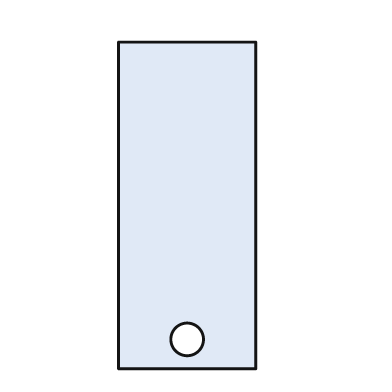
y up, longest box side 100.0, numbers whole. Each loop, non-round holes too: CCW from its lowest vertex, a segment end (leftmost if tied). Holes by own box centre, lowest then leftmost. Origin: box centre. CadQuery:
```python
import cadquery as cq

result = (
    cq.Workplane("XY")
    .moveTo(-21.0, -50.0)
    .lineTo(21.0, -50.0)
    .lineTo(21.0, 50.0)
    .lineTo(-21.0, 50.0)
    .close()
    .moveTo(0.0, -41.0)
    .circle(5.0)
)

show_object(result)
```